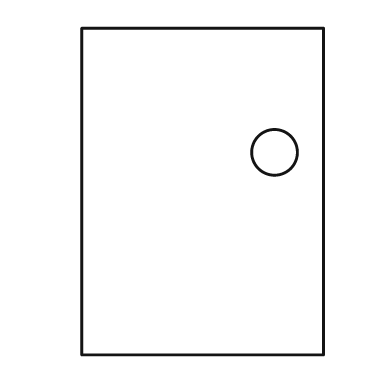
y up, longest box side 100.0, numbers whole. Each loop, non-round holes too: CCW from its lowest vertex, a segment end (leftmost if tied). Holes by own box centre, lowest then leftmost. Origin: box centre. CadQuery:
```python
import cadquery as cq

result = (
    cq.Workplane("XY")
    .moveTo(-37.0, -50.0)
    .lineTo(37.0, -50.0)
    .lineTo(37.0, 50.0)
    .lineTo(-37.0, 50.0)
    .close()
    .moveTo(22.0, 12.0)
    .circle(7.0)
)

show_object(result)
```